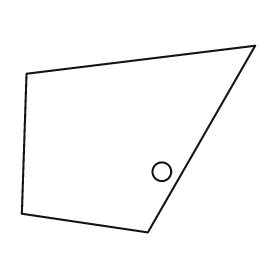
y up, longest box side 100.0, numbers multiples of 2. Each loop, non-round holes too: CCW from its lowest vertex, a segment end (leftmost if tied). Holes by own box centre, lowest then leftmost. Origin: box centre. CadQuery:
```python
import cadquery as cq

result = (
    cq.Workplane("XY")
    .moveTo(4.0, -40.0)
    .lineTo(50.0, 40.0)
    .lineTo(-48.0, 28.0)
    .lineTo(-50.0, -32.0)
    .close()
    .moveTo(10.0, -14.0)
    .circle(4.0)
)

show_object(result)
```